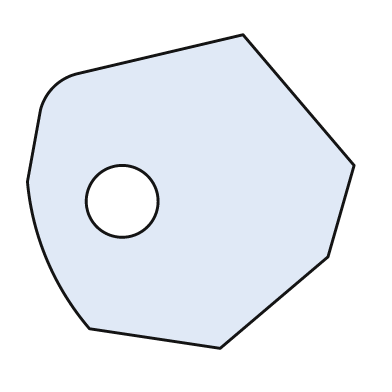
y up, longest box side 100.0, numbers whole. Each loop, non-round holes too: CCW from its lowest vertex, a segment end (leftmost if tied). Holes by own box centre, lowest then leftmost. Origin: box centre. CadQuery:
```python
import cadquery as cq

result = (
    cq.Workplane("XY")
    .moveTo(9.0, -48.0)
    .lineTo(42.0, -20.0)
    .lineTo(50.0, 8.0)
    .lineTo(16.0, 48.0)
    .lineTo(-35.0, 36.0)
    .threePointArc((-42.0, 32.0), (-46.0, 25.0))
    .lineTo(-50.0, 3.0)
    .threePointArc((-44.0, -21.0), (-31.0, -42.0))
    .close()
    .moveTo(-21.0, -3.0)
    .circle(11.0)
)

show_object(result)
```